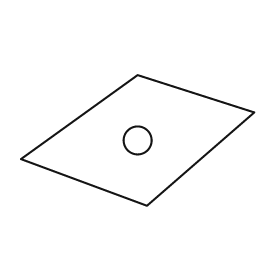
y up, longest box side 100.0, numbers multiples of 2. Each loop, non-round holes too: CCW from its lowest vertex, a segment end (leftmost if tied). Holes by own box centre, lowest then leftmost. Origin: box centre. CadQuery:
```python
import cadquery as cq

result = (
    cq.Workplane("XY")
    .moveTo(4.0, -28.0)
    .lineTo(50.0, 12.0)
    .lineTo(0.0, 28.0)
    .lineTo(-50.0, -8.0)
    .close()
    .moveTo(0.0, 0.0)
    .circle(6.0)
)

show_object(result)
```